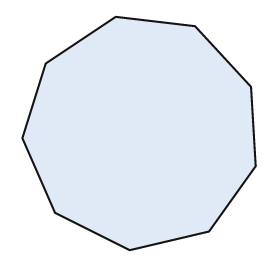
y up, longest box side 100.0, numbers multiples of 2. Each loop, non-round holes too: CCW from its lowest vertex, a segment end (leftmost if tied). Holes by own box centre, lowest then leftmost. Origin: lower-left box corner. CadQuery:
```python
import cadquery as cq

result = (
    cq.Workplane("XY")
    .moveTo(46.0, 0.0)
    .lineTo(80.0, 8.0)
    .lineTo(100.0, 36.0)
    .lineTo(98.0, 70.0)
    .lineTo(74.0, 96.0)
    .lineTo(40.0, 100.0)
    .lineTo(10.0, 80.0)
    .lineTo(0.0, 48.0)
    .lineTo(14.0, 16.0)
    .close()
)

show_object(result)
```